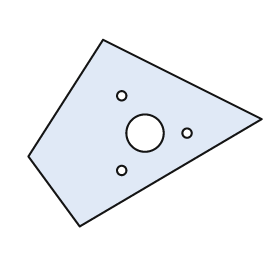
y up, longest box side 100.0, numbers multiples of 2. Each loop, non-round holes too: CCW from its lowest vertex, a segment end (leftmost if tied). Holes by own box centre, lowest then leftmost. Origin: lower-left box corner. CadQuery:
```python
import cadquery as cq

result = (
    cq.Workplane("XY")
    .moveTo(22.0, 0.0)
    .lineTo(100.0, 46.0)
    .lineTo(32.0, 80.0)
    .lineTo(0.0, 30.0)
    .close()
    .moveTo(40.0, 24.0)
    .circle(2.0)
    .moveTo(50.0, 40.0)
    .circle(8.0)
    .moveTo(68.0, 40.0)
    .circle(2.0)
    .moveTo(40.0, 56.0)
    .circle(2.0)
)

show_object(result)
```